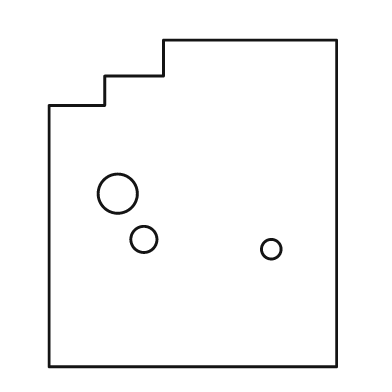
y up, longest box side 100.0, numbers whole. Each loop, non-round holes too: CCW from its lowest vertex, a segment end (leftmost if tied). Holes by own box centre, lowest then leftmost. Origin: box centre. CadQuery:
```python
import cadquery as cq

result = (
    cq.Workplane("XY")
    .moveTo(-44.0, -50.0)
    .lineTo(44.0, -50.0)
    .lineTo(44.0, 50.0)
    .lineTo(-9.0, 50.0)
    .lineTo(-9.0, 39.0)
    .lineTo(-27.0, 39.0)
    .lineTo(-27.0, 30.0)
    .lineTo(-44.0, 30.0)
    .close()
    .moveTo(24.0, -14.0)
    .circle(3.0)
    .moveTo(-15.0, -11.0)
    .circle(4.0)
    .moveTo(-23.0, 3.0)
    .circle(6.0)
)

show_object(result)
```